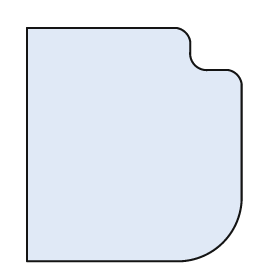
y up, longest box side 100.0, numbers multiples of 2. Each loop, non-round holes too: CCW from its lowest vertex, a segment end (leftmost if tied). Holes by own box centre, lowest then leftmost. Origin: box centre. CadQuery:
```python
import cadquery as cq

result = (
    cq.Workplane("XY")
    .moveTo(-46.0, -50.0)
    .lineTo(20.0, -50.0)
    .threePointArc((38.0, -42.0), (46.0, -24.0))
    .lineTo(46.0, 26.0)
    .threePointArc((44.0, 30.0), (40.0, 32.0))
    .lineTo(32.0, 32.0)
    .threePointArc((26.0, 34.0), (24.0, 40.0))
    .lineTo(24.0, 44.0)
    .threePointArc((22.0, 48.0), (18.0, 50.0))
    .lineTo(-46.0, 50.0)
    .close()
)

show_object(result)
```